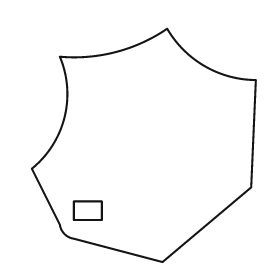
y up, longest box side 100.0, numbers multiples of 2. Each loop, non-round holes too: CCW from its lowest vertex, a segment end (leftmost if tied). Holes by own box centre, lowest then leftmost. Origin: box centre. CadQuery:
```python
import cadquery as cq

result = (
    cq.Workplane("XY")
    .moveTo(8.0, -50.0)
    .lineTo(46.0, -18.0)
    .lineTo(48.0, 28.0)
    .threePointArc((26.0, 34.0), (10.0, 50.0))
    .threePointArc((-12.0, 40.0), (-36.0, 38.0))
    .threePointArc((-34.0, 12.0), (-48.0, -10.0))
    .lineTo(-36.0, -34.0)
    .threePointArc((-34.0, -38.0), (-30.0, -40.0))
    .close()
    .moveTo(-30.0, -32.0)
    .lineTo(-18.0, -32.0)
    .lineTo(-18.0, -24.0)
    .lineTo(-30.0, -24.0)
    .close()
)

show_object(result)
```